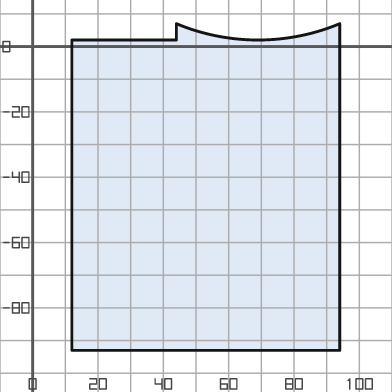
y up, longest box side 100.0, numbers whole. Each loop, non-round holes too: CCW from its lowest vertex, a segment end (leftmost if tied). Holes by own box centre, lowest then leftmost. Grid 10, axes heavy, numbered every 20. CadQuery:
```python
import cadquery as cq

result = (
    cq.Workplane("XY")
    .moveTo(12.0, -93.0)
    .lineTo(94.0, -93.0)
    .lineTo(94.0, 7.0)
    .threePointArc((69.0, 2.0), (44.0, 7.0))
    .lineTo(44.0, 2.0)
    .lineTo(12.0, 2.0)
    .close()
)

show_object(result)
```